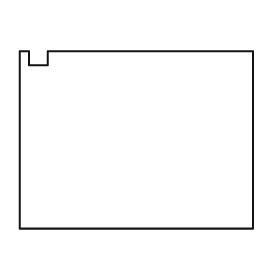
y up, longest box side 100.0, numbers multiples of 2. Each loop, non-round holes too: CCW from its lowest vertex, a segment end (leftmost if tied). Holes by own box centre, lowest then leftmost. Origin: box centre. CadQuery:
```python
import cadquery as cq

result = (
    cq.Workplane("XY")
    .moveTo(-50.0, -38.0)
    .lineTo(50.0, -38.0)
    .lineTo(50.0, 38.0)
    .lineTo(-38.0, 38.0)
    .lineTo(-38.0, 32.0)
    .lineTo(-46.0, 32.0)
    .lineTo(-46.0, 38.0)
    .lineTo(-50.0, 38.0)
    .close()
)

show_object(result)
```